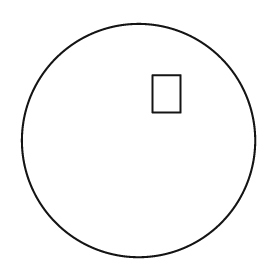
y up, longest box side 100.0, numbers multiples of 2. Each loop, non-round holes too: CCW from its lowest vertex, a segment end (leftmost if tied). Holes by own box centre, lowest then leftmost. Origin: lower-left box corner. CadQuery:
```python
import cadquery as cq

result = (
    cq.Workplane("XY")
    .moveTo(50.0, 50.0)
    .circle(50.0)
    .moveTo(56.0, 62.0)
    .lineTo(68.0, 62.0)
    .lineTo(68.0, 78.0)
    .lineTo(56.0, 78.0)
    .close()
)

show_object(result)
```